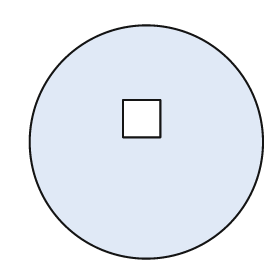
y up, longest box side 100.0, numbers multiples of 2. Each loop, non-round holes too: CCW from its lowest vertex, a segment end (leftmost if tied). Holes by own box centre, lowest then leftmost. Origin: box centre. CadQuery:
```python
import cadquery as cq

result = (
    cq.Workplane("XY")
    .moveTo(0.0, 0.0)
    .circle(50.0)
    .moveTo(-10.0, 2.0)
    .lineTo(6.0, 2.0)
    .lineTo(6.0, 18.0)
    .lineTo(-10.0, 18.0)
    .close()
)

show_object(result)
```